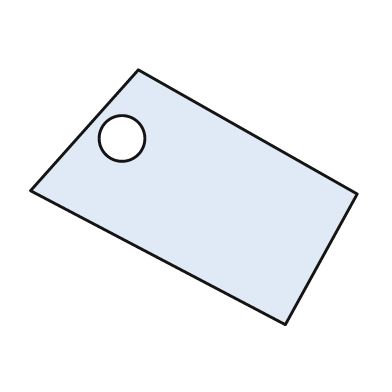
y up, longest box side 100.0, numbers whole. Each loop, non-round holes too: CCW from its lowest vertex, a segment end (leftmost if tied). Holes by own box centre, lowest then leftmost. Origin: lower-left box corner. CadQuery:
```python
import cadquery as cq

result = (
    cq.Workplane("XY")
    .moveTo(78.0, 0.0)
    .lineTo(100.0, 40.0)
    .lineTo(33.0, 78.0)
    .lineTo(0.0, 41.0)
    .close()
    .moveTo(28.0, 57.0)
    .circle(7.0)
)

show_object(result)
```